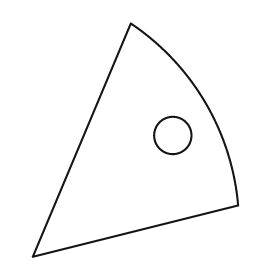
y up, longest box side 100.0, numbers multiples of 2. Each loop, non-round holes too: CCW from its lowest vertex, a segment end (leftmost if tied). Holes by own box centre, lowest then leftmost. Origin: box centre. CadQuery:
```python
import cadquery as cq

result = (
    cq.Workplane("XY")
    .moveTo(-44.0, -50.0)
    .lineTo(44.0, -28.0)
    .threePointArc((30.0, 16.0), (-2.0, 50.0))
    .close()
    .moveTo(16.0, 2.0)
    .circle(8.0)
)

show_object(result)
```